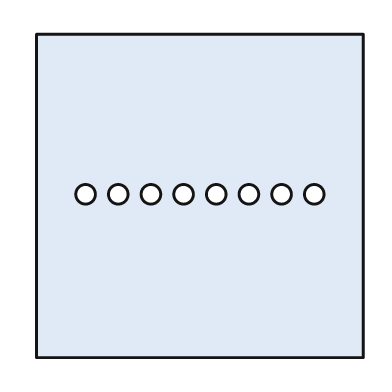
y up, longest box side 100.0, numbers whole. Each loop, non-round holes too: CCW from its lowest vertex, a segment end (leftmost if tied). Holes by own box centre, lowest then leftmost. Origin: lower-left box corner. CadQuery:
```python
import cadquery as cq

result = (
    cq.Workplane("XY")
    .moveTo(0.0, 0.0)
    .lineTo(100.0, 0.0)
    .lineTo(100.0, 99.0)
    .lineTo(0.0, 99.0)
    .close()
    .moveTo(15.0, 50.0)
    .circle(3.0)
    .moveTo(25.0, 50.0)
    .circle(3.0)
    .moveTo(35.0, 50.0)
    .circle(3.0)
    .moveTo(45.0, 50.0)
    .circle(3.0)
    .moveTo(55.0, 50.0)
    .circle(3.0)
    .moveTo(65.0, 50.0)
    .circle(3.0)
    .moveTo(75.0, 50.0)
    .circle(3.0)
    .moveTo(85.0, 50.0)
    .circle(3.0)
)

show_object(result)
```